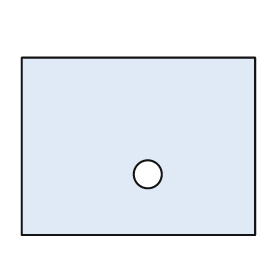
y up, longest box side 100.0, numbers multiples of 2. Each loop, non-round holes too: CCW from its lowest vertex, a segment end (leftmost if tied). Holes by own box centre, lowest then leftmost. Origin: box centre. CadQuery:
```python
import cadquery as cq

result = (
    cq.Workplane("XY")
    .moveTo(-50.0, -38.0)
    .lineTo(50.0, -38.0)
    .lineTo(50.0, 38.0)
    .lineTo(-50.0, 38.0)
    .close()
    .moveTo(4.0, -12.0)
    .circle(6.0)
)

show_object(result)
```